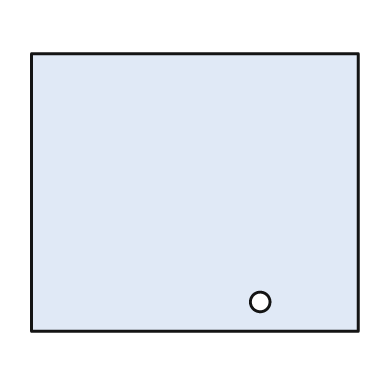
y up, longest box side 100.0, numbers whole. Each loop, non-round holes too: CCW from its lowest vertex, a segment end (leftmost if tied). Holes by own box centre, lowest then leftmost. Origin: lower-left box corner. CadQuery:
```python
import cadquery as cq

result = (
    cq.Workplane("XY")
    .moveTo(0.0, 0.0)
    .lineTo(100.0, 0.0)
    .lineTo(100.0, 85.0)
    .lineTo(0.0, 85.0)
    .close()
    .moveTo(70.0, 9.0)
    .circle(3.0)
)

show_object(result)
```